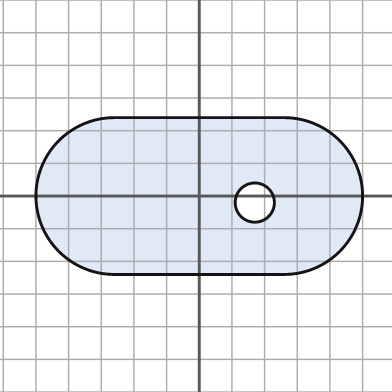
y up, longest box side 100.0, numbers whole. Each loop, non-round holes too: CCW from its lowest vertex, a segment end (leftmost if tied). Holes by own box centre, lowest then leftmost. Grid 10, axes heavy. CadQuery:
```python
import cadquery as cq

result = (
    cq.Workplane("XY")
    .moveTo(-26.0, -24.0)
    .lineTo(26.0, -24.0)
    .threePointArc((50.0, 0.0), (26.0, 24.0))
    .lineTo(-26.0, 24.0)
    .threePointArc((-50.0, 0.0), (-26.0, -24.0))
    .close()
    .moveTo(17.0, -2.0)
    .circle(6.0)
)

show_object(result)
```